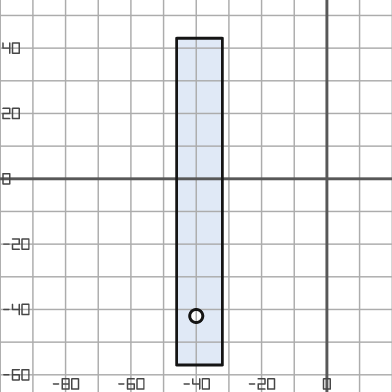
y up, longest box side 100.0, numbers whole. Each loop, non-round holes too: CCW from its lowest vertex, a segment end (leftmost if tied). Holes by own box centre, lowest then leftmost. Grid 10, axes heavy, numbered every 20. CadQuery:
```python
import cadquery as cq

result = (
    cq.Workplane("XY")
    .moveTo(-46.0, -57.0)
    .lineTo(-32.0, -57.0)
    .lineTo(-32.0, 43.0)
    .lineTo(-46.0, 43.0)
    .close()
    .moveTo(-40.0, -42.0)
    .circle(2.0)
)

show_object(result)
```